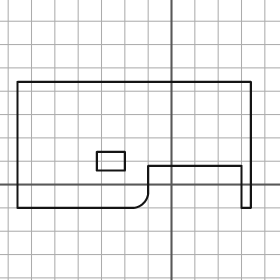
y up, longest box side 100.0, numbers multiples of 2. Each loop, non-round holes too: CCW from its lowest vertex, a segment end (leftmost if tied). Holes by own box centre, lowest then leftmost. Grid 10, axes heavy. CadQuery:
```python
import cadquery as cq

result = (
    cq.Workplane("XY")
    .moveTo(-66.0, -10.0)
    .lineTo(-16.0, -10.0)
    .threePointArc((-12.0, -8.0), (-10.0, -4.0))
    .lineTo(-10.0, 8.0)
    .lineTo(30.0, 8.0)
    .lineTo(30.0, -10.0)
    .lineTo(34.0, -10.0)
    .lineTo(34.0, 44.0)
    .lineTo(-66.0, 44.0)
    .close()
    .moveTo(-32.0, 6.0)
    .lineTo(-20.0, 6.0)
    .lineTo(-20.0, 14.0)
    .lineTo(-32.0, 14.0)
    .close()
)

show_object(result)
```